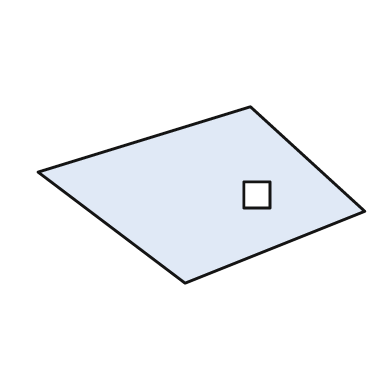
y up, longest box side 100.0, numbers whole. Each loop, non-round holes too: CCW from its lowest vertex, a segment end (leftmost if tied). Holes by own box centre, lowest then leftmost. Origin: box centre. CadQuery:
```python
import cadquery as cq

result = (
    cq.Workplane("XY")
    .moveTo(-5.0, -27.0)
    .lineTo(50.0, -5.0)
    .lineTo(15.0, 27.0)
    .lineTo(-50.0, 7.0)
    .close()
    .moveTo(13.0, -4.0)
    .lineTo(21.0, -4.0)
    .lineTo(21.0, 4.0)
    .lineTo(13.0, 4.0)
    .close()
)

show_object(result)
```